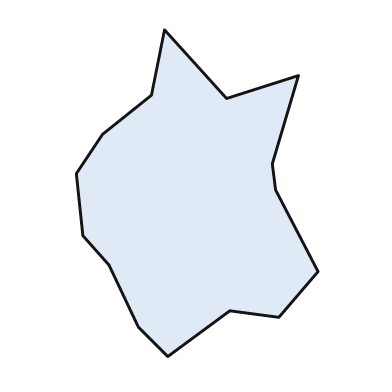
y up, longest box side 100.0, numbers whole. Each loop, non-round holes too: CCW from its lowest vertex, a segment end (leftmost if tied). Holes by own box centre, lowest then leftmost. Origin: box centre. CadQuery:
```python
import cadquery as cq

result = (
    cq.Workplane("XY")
    .moveTo(-9.0, -50.0)
    .lineTo(10.0, -36.0)
    .lineTo(25.0, -38.0)
    .lineTo(37.0, -24.0)
    .lineTo(24.0, 1.0)
    .lineTo(23.0, 9.0)
    .lineTo(31.0, 36.0)
    .lineTo(9.0, 29.0)
    .lineTo(-10.0, 50.0)
    .lineTo(-14.0, 30.0)
    .lineTo(-29.0, 18.0)
    .lineTo(-37.0, 6.0)
    .lineTo(-35.0, -13.0)
    .lineTo(-27.0, -22.0)
    .lineTo(-18.0, -41.0)
    .close()
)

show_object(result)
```